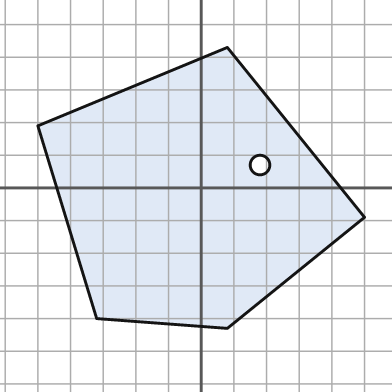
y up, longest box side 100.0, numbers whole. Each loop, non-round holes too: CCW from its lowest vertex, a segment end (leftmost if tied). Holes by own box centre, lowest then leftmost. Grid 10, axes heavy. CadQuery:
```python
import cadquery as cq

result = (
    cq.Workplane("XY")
    .moveTo(8.0, -43.0)
    .lineTo(50.0, -9.0)
    .lineTo(8.0, 43.0)
    .lineTo(-50.0, 19.0)
    .lineTo(-32.0, -40.0)
    .close()
    .moveTo(18.0, 7.0)
    .circle(3.0)
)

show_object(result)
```